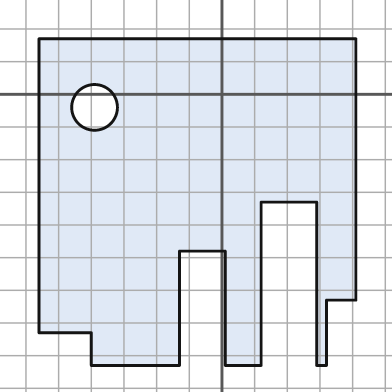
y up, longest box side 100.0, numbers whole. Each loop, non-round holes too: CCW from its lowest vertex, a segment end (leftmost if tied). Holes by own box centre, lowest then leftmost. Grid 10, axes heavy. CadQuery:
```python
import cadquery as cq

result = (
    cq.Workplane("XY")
    .moveTo(-40.0, -83.0)
    .lineTo(-13.0, -83.0)
    .lineTo(-13.0, -48.0)
    .lineTo(1.0, -48.0)
    .lineTo(1.0, -83.0)
    .lineTo(12.0, -83.0)
    .lineTo(12.0, -33.0)
    .lineTo(29.0, -33.0)
    .lineTo(29.0, -83.0)
    .lineTo(32.0, -83.0)
    .lineTo(32.0, -63.0)
    .lineTo(41.0, -63.0)
    .lineTo(41.0, 17.0)
    .lineTo(-56.0, 17.0)
    .lineTo(-56.0, -73.0)
    .lineTo(-40.0, -73.0)
    .close()
    .moveTo(-39.0, -4.0)
    .circle(7.0)
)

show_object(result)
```